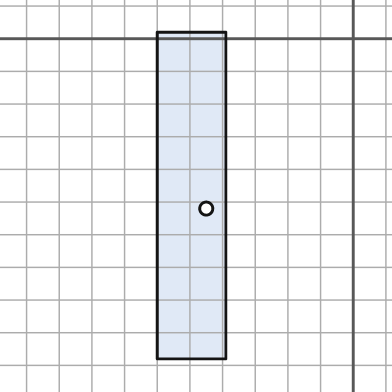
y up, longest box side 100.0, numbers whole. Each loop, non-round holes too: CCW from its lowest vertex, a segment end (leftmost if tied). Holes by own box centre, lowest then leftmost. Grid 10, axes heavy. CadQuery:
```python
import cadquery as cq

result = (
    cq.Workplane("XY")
    .moveTo(-60.0, -98.0)
    .lineTo(-39.0, -98.0)
    .lineTo(-39.0, 2.0)
    .lineTo(-60.0, 2.0)
    .close()
    .moveTo(-45.0, -52.0)
    .circle(2.0)
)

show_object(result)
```